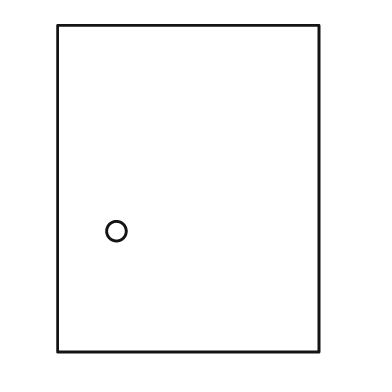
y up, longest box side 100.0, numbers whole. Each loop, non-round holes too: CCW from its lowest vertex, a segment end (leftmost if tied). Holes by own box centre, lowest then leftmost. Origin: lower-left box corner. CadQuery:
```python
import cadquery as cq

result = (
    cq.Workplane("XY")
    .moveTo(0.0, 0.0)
    .lineTo(80.0, 0.0)
    .lineTo(80.0, 100.0)
    .lineTo(0.0, 100.0)
    .close()
    .moveTo(18.0, 37.0)
    .circle(3.0)
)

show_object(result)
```